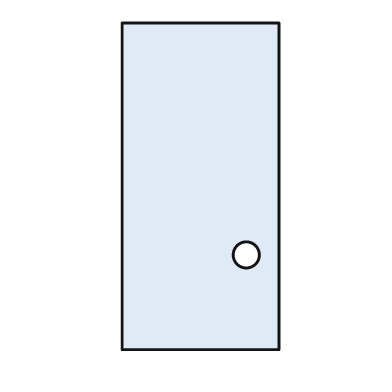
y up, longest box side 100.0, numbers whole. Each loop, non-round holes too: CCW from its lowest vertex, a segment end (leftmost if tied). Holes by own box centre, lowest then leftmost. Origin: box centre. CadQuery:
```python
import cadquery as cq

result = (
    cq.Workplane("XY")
    .moveTo(-24.0, -50.0)
    .lineTo(24.0, -50.0)
    .lineTo(24.0, 50.0)
    .lineTo(-24.0, 50.0)
    .close()
    .moveTo(14.0, -21.0)
    .circle(4.0)
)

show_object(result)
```